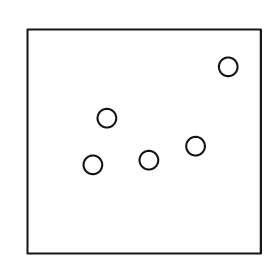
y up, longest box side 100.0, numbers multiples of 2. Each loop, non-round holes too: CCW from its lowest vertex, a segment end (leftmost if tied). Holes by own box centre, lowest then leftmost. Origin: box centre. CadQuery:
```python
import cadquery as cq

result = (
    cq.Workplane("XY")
    .moveTo(-50.0, -48.0)
    .lineTo(50.0, -48.0)
    .lineTo(50.0, 48.0)
    .lineTo(-50.0, 48.0)
    .close()
    .moveTo(-22.0, -10.0)
    .circle(4.0)
    .moveTo(2.0, -8.0)
    .circle(4.0)
    .moveTo(22.0, -2.0)
    .circle(4.0)
    .moveTo(-16.0, 10.0)
    .circle(4.0)
    .moveTo(36.0, 32.0)
    .circle(4.0)
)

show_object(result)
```